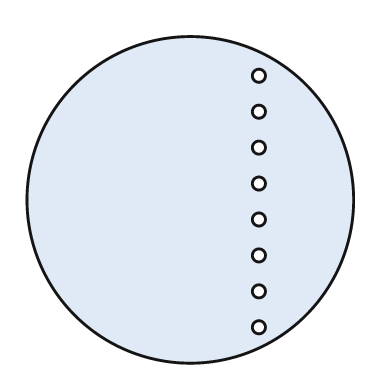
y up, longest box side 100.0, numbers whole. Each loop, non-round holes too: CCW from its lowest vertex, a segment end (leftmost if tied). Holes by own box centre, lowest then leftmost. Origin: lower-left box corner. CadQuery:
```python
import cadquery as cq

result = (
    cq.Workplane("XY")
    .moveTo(50.0, 50.0)
    .circle(50.0)
    .moveTo(71.0, 11.0)
    .circle(2.0)
    .moveTo(71.0, 22.0)
    .circle(2.0)
    .moveTo(71.0, 33.0)
    .circle(2.0)
    .moveTo(71.0, 44.0)
    .circle(2.0)
    .moveTo(71.0, 55.0)
    .circle(2.0)
    .moveTo(71.0, 66.0)
    .circle(2.0)
    .moveTo(71.0, 77.0)
    .circle(2.0)
    .moveTo(71.0, 88.0)
    .circle(2.0)
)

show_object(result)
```